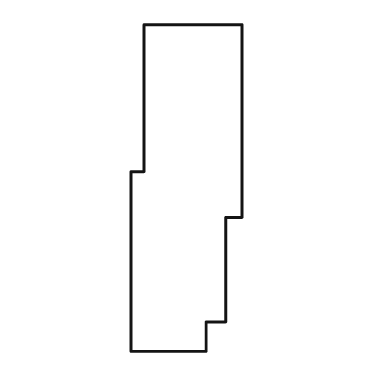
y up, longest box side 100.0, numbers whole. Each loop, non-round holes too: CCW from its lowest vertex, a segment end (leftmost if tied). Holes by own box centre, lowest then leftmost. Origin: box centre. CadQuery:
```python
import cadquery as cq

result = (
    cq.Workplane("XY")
    .moveTo(-17.0, -50.0)
    .lineTo(6.0, -50.0)
    .lineTo(6.0, -41.0)
    .lineTo(12.0, -41.0)
    .lineTo(12.0, -9.0)
    .lineTo(17.0, -9.0)
    .lineTo(17.0, 50.0)
    .lineTo(-13.0, 50.0)
    .lineTo(-13.0, 5.0)
    .lineTo(-17.0, 5.0)
    .close()
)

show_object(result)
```